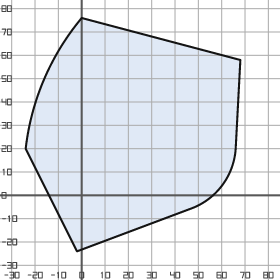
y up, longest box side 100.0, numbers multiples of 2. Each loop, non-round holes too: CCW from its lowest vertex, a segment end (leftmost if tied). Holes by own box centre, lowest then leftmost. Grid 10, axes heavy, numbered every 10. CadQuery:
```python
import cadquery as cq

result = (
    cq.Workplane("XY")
    .moveTo(-2.0, -24.0)
    .lineTo(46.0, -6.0)
    .threePointArc((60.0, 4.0), (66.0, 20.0))
    .lineTo(68.0, 58.0)
    .lineTo(0.0, 76.0)
    .threePointArc((-16.0, 50.0), (-24.0, 20.0))
    .close()
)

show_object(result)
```